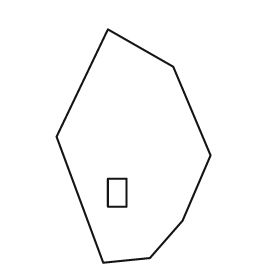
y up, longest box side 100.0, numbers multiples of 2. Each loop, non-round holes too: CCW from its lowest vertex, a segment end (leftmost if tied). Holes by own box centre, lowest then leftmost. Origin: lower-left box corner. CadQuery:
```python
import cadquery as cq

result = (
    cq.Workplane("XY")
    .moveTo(20.0, 0.0)
    .lineTo(40.0, 2.0)
    .lineTo(54.0, 18.0)
    .lineTo(66.0, 46.0)
    .lineTo(50.0, 84.0)
    .lineTo(22.0, 100.0)
    .lineTo(0.0, 54.0)
    .close()
    .moveTo(22.0, 24.0)
    .lineTo(30.0, 24.0)
    .lineTo(30.0, 36.0)
    .lineTo(22.0, 36.0)
    .close()
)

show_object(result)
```